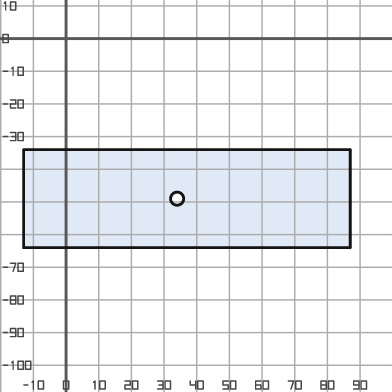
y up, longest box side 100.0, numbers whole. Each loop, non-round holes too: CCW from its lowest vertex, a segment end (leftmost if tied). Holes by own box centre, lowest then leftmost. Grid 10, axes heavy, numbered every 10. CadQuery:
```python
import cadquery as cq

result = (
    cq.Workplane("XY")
    .moveTo(-13.0, -64.0)
    .lineTo(87.0, -64.0)
    .lineTo(87.0, -34.0)
    .lineTo(-13.0, -34.0)
    .close()
    .moveTo(34.0, -49.0)
    .circle(2.0)
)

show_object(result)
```